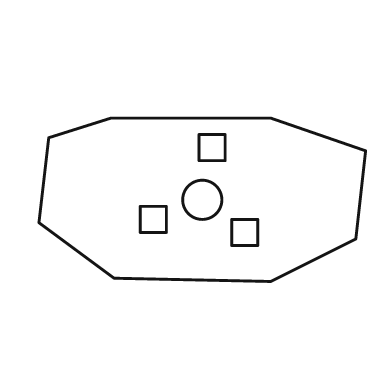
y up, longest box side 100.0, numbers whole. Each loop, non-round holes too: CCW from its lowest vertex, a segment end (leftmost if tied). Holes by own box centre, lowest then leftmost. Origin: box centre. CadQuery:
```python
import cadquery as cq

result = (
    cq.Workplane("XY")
    .moveTo(21.0, -25.0)
    .lineTo(47.0, -12.0)
    .lineTo(50.0, 15.0)
    .lineTo(21.0, 25.0)
    .lineTo(-28.0, 25.0)
    .lineTo(-47.0, 19.0)
    .lineTo(-50.0, -7.0)
    .lineTo(-27.0, -24.0)
    .close()
    .moveTo(9.0, -14.0)
    .lineTo(17.0, -14.0)
    .lineTo(17.0, -6.0)
    .lineTo(9.0, -6.0)
    .close()
    .moveTo(-19.0, -10.0)
    .lineTo(-11.0, -10.0)
    .lineTo(-11.0, -2.0)
    .lineTo(-19.0, -2.0)
    .close()
    .moveTo(0.0, 0.0)
    .circle(6.0)
    .moveTo(-1.0, 12.0)
    .lineTo(7.0, 12.0)
    .lineTo(7.0, 20.0)
    .lineTo(-1.0, 20.0)
    .close()
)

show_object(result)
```